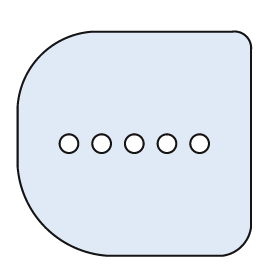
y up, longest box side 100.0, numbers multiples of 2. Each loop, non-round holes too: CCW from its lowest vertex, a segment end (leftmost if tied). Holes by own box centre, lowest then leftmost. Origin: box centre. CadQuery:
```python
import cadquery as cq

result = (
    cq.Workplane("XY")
    .moveTo(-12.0, -48.0)
    .lineTo(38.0, -48.0)
    .threePointArc((46.0, -44.0), (50.0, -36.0))
    .lineTo(50.0, 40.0)
    .threePointArc((48.0, 46.0), (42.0, 48.0))
    .lineTo(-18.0, 48.0)
    .threePointArc((-40.0, 38.0), (-50.0, 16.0))
    .lineTo(-50.0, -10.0)
    .threePointArc((-38.0, -36.0), (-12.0, -48.0))
    .close()
    .moveTo(-28.0, 0.0)
    .circle(4.0)
    .moveTo(-14.0, 0.0)
    .circle(4.0)
    .moveTo(0.0, 0.0)
    .circle(4.0)
    .moveTo(14.0, 0.0)
    .circle(4.0)
    .moveTo(28.0, 0.0)
    .circle(4.0)
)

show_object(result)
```